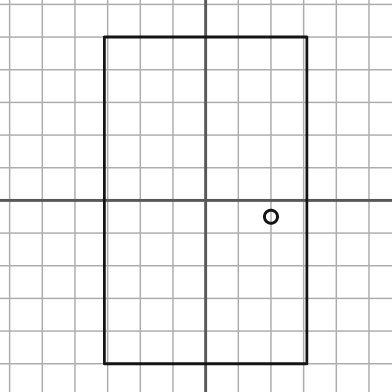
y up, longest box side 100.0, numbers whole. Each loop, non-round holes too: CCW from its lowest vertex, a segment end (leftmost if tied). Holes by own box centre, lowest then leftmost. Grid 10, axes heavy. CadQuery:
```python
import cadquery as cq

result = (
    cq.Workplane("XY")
    .moveTo(-31.0, -50.0)
    .lineTo(31.0, -50.0)
    .lineTo(31.0, 50.0)
    .lineTo(-31.0, 50.0)
    .close()
    .moveTo(20.0, -5.0)
    .circle(2.0)
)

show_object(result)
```